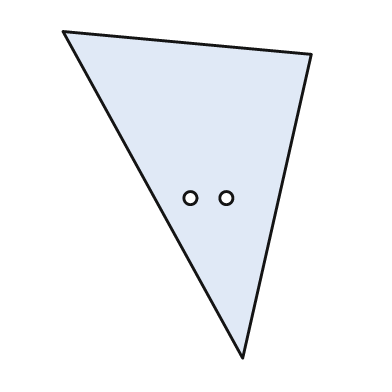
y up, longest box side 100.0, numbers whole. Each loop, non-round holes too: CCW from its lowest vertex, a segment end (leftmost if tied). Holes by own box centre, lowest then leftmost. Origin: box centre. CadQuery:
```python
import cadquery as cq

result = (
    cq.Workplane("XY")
    .moveTo(17.0, -50.0)
    .lineTo(38.0, 43.0)
    .lineTo(-38.0, 50.0)
    .close()
    .moveTo(1.0, -1.0)
    .circle(2.0)
    .moveTo(12.0, -1.0)
    .circle(2.0)
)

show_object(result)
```